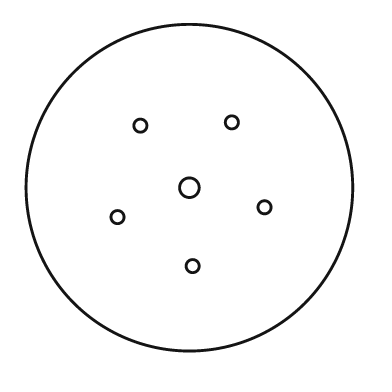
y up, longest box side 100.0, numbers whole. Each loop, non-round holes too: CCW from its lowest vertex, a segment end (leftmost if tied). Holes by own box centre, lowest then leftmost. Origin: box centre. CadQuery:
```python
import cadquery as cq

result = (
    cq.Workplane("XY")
    .moveTo(0.0, 0.0)
    .circle(50.0)
    .moveTo(1.0, -24.0)
    .circle(2.0)
    .moveTo(-22.0, -9.0)
    .circle(2.0)
    .moveTo(23.0, -6.0)
    .circle(2.0)
    .moveTo(0.0, 0.0)
    .circle(3.0)
    .moveTo(-15.0, 19.0)
    .circle(2.0)
    .moveTo(13.0, 20.0)
    .circle(2.0)
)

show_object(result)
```